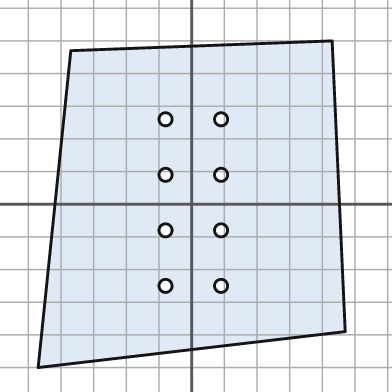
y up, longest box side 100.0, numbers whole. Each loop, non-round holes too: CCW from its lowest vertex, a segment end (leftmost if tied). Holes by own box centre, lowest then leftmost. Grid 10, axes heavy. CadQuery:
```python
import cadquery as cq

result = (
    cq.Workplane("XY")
    .moveTo(-47.0, -50.0)
    .lineTo(47.0, -39.0)
    .lineTo(43.0, 50.0)
    .lineTo(-37.0, 47.0)
    .close()
    .moveTo(-8.0, -25.0)
    .circle(2.0)
    .moveTo(9.0, -25.0)
    .circle(2.0)
    .moveTo(-8.0, -8.0)
    .circle(2.0)
    .moveTo(9.0, -8.0)
    .circle(2.0)
    .moveTo(-8.0, 9.0)
    .circle(2.0)
    .moveTo(9.0, 9.0)
    .circle(2.0)
    .moveTo(-8.0, 26.0)
    .circle(2.0)
    .moveTo(9.0, 26.0)
    .circle(2.0)
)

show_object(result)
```